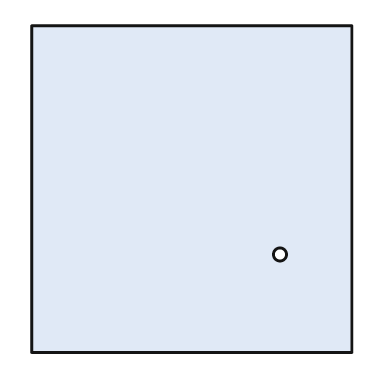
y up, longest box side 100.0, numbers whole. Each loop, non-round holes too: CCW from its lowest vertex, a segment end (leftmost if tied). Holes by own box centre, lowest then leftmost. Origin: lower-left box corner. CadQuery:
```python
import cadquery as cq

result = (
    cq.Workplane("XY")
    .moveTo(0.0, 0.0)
    .lineTo(98.0, 0.0)
    .lineTo(98.0, 100.0)
    .lineTo(0.0, 100.0)
    .close()
    .moveTo(76.0, 30.0)
    .circle(2.0)
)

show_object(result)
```